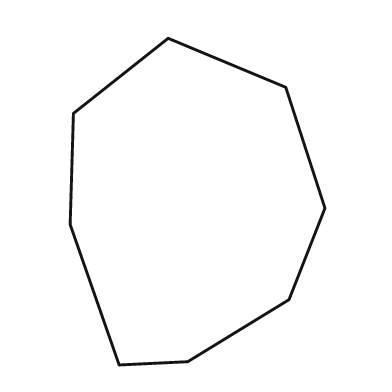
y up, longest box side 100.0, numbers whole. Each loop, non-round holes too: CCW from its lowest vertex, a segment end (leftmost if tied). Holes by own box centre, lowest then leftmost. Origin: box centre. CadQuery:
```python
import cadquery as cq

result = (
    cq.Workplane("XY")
    .moveTo(-24.0, -50.0)
    .lineTo(-3.0, -49.0)
    .lineTo(28.0, -30.0)
    .lineTo(39.0, -2.0)
    .lineTo(27.0, 35.0)
    .lineTo(-9.0, 50.0)
    .lineTo(-38.0, 27.0)
    .lineTo(-39.0, -7.0)
    .close()
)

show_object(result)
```